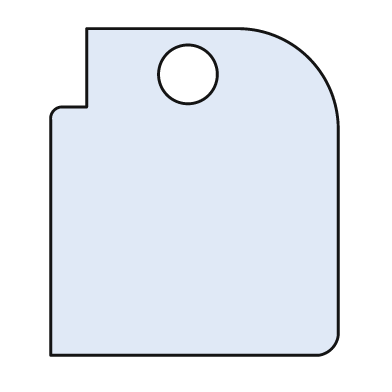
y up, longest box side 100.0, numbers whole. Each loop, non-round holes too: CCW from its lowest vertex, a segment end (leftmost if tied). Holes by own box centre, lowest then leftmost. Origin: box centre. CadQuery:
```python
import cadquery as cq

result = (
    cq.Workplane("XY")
    .moveTo(-44.0, -50.0)
    .lineTo(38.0, -50.0)
    .threePointArc((42.0, -48.0), (44.0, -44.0))
    .lineTo(44.0, 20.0)
    .threePointArc((35.0, 41.0), (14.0, 50.0))
    .lineTo(-33.0, 50.0)
    .lineTo(-33.0, 26.0)
    .lineTo(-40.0, 26.0)
    .threePointArc((-43.0, 25.0), (-44.0, 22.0))
    .close()
    .moveTo(-2.0, 36.0)
    .circle(9.0)
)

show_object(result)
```